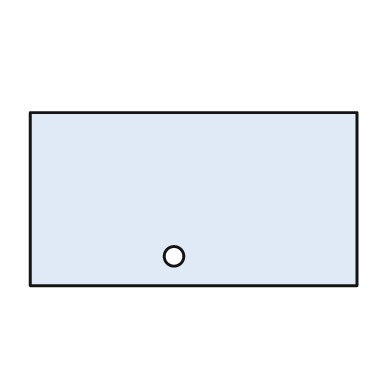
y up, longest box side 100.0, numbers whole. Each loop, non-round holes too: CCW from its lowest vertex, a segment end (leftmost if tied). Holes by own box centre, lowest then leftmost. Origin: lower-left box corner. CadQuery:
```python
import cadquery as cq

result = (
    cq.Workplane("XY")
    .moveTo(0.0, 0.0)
    .lineTo(100.0, 0.0)
    .lineTo(100.0, 53.0)
    .lineTo(0.0, 53.0)
    .close()
    .moveTo(44.0, 9.0)
    .circle(3.0)
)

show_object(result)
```